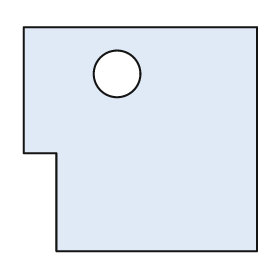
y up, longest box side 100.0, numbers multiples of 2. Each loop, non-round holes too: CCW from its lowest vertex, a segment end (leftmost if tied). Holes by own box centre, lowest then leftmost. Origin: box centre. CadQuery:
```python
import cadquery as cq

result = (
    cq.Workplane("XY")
    .moveTo(-36.0, -48.0)
    .lineTo(50.0, -48.0)
    .lineTo(50.0, 48.0)
    .lineTo(-50.0, 48.0)
    .lineTo(-50.0, -6.0)
    .lineTo(-36.0, -6.0)
    .close()
    .moveTo(-10.0, 28.0)
    .circle(10.0)
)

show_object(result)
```